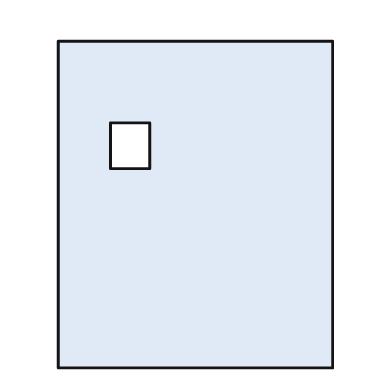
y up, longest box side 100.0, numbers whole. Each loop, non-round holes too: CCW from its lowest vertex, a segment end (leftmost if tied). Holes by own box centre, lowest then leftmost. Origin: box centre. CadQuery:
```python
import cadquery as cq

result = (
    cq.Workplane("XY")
    .moveTo(-42.0, -50.0)
    .lineTo(42.0, -50.0)
    .lineTo(42.0, 50.0)
    .lineTo(-42.0, 50.0)
    .close()
    .moveTo(-26.0, 11.0)
    .lineTo(-14.0, 11.0)
    .lineTo(-14.0, 25.0)
    .lineTo(-26.0, 25.0)
    .close()
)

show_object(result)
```